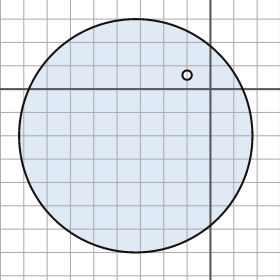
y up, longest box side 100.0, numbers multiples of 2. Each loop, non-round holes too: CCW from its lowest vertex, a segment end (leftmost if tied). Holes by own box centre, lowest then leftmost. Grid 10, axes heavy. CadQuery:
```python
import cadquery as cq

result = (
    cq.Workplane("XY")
    .moveTo(-32.0, -20.0)
    .circle(50.0)
    .moveTo(-10.0, 6.0)
    .circle(2.0)
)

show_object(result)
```